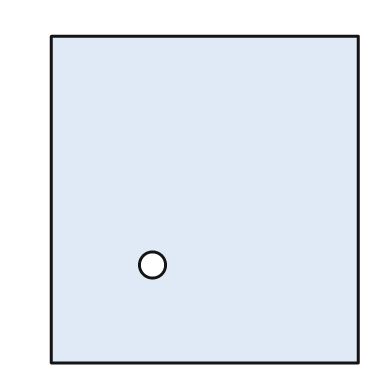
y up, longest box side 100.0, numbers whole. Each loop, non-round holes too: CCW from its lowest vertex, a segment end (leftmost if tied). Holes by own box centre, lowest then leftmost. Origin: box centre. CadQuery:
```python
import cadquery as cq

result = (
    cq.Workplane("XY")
    .moveTo(-47.0, -50.0)
    .lineTo(47.0, -50.0)
    .lineTo(47.0, 50.0)
    .lineTo(-47.0, 50.0)
    .close()
    .moveTo(-16.0, -20.0)
    .circle(4.0)
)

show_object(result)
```